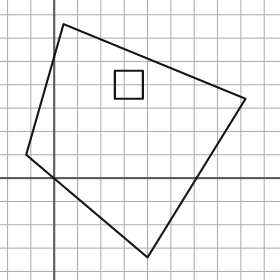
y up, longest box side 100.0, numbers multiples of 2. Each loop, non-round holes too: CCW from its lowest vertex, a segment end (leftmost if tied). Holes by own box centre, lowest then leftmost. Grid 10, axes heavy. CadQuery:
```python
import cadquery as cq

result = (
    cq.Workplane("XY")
    .moveTo(40.0, -34.0)
    .lineTo(82.0, 34.0)
    .lineTo(4.0, 66.0)
    .lineTo(-12.0, 10.0)
    .close()
    .moveTo(26.0, 34.0)
    .lineTo(38.0, 34.0)
    .lineTo(38.0, 46.0)
    .lineTo(26.0, 46.0)
    .close()
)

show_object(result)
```